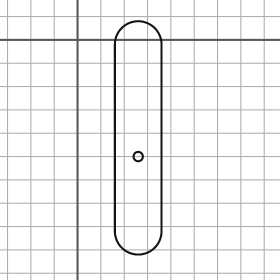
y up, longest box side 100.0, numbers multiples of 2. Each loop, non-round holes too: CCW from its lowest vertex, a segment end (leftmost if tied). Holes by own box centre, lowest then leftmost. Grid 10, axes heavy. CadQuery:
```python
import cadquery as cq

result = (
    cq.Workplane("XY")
    .moveTo(16.0, -82.0)
    .threePointArc((26.0, -92.0), (36.0, -82.0))
    .lineTo(36.0, -2.0)
    .threePointArc((26.0, 8.0), (16.0, -2.0))
    .close()
    .moveTo(26.0, -50.0)
    .circle(2.0)
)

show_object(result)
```